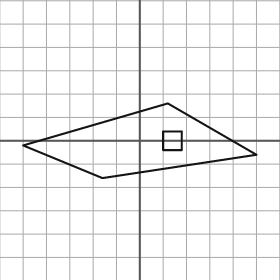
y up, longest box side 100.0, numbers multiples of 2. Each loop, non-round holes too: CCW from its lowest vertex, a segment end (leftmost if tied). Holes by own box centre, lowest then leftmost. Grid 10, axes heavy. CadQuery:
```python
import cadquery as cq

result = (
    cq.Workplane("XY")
    .moveTo(-16.0, -16.0)
    .lineTo(50.0, -6.0)
    .lineTo(12.0, 16.0)
    .lineTo(-50.0, -2.0)
    .close()
    .moveTo(10.0, -4.0)
    .lineTo(18.0, -4.0)
    .lineTo(18.0, 4.0)
    .lineTo(10.0, 4.0)
    .close()
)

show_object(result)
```